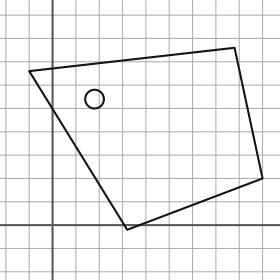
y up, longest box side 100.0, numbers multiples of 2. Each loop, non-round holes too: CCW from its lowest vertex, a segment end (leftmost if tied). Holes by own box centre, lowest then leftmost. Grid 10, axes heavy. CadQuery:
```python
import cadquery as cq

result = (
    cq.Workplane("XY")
    .moveTo(32.0, -2.0)
    .lineTo(90.0, 20.0)
    .lineTo(78.0, 76.0)
    .lineTo(-10.0, 66.0)
    .close()
    .moveTo(18.0, 54.0)
    .circle(4.0)
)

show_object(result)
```